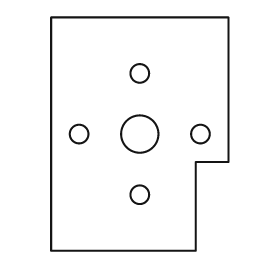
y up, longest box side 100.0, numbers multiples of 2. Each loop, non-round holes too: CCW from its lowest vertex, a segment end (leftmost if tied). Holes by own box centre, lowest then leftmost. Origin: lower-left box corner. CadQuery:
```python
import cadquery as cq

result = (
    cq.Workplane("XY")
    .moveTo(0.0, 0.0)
    .lineTo(62.0, 0.0)
    .lineTo(62.0, 38.0)
    .lineTo(76.0, 38.0)
    .lineTo(76.0, 100.0)
    .lineTo(0.0, 100.0)
    .close()
    .moveTo(38.0, 24.0)
    .circle(4.0)
    .moveTo(12.0, 50.0)
    .circle(4.0)
    .moveTo(38.0, 50.0)
    .circle(8.0)
    .moveTo(64.0, 50.0)
    .circle(4.0)
    .moveTo(38.0, 76.0)
    .circle(4.0)
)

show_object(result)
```